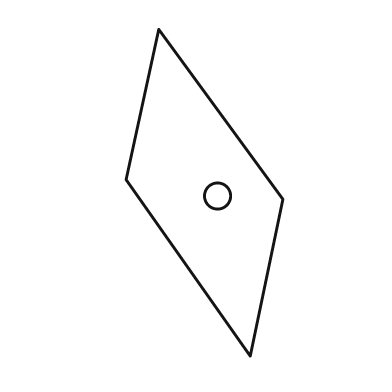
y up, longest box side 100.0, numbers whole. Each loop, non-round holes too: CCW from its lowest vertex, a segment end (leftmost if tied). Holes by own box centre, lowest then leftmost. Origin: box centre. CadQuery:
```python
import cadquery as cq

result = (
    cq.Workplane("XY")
    .moveTo(14.0, -50.0)
    .lineTo(24.0, -2.0)
    .lineTo(-14.0, 50.0)
    .lineTo(-24.0, 4.0)
    .close()
    .moveTo(4.0, -1.0)
    .circle(4.0)
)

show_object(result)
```